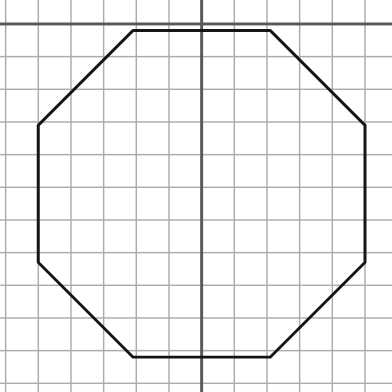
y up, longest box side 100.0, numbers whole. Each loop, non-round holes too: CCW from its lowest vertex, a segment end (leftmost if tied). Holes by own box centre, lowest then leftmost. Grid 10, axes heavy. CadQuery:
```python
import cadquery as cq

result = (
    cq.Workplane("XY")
    .moveTo(-21.0, -102.0)
    .lineTo(21.0, -102.0)
    .lineTo(50.0, -73.0)
    .lineTo(50.0, -31.0)
    .lineTo(21.0, -2.0)
    .lineTo(-21.0, -2.0)
    .lineTo(-50.0, -31.0)
    .lineTo(-50.0, -73.0)
    .close()
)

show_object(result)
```